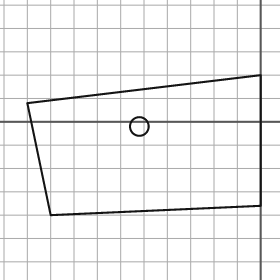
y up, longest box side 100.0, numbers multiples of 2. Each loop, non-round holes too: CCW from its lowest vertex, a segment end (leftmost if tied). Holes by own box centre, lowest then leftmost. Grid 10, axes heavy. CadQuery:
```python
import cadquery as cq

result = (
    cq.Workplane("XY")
    .moveTo(-90.0, -40.0)
    .lineTo(0.0, -36.0)
    .lineTo(0.0, 20.0)
    .lineTo(-100.0, 8.0)
    .close()
    .moveTo(-52.0, -2.0)
    .circle(4.0)
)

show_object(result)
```